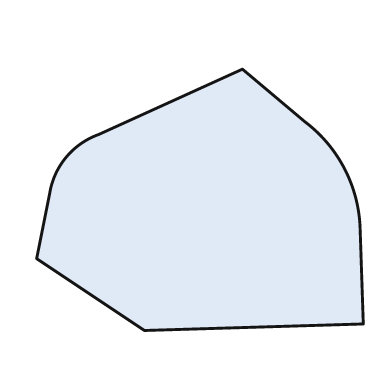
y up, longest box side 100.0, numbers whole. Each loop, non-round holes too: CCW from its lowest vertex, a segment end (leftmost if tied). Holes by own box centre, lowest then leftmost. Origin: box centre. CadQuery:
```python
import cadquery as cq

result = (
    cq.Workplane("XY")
    .moveTo(-17.0, -40.0)
    .lineTo(50.0, -38.0)
    .lineTo(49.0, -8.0)
    .threePointArc((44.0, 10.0), (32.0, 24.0))
    .lineTo(13.0, 40.0)
    .lineTo(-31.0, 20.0)
    .threePointArc((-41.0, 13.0), (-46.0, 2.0))
    .lineTo(-50.0, -18.0)
    .close()
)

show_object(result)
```